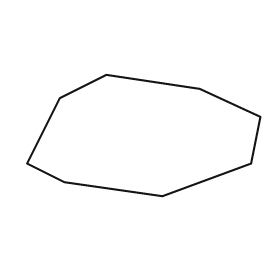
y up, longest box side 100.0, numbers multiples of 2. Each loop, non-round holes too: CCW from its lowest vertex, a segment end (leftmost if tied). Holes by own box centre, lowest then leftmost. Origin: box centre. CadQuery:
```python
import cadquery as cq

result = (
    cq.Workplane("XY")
    .moveTo(8.0, -26.0)
    .lineTo(46.0, -12.0)
    .lineTo(50.0, 8.0)
    .lineTo(24.0, 20.0)
    .lineTo(-16.0, 26.0)
    .lineTo(-36.0, 16.0)
    .lineTo(-50.0, -12.0)
    .lineTo(-34.0, -20.0)
    .close()
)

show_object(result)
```